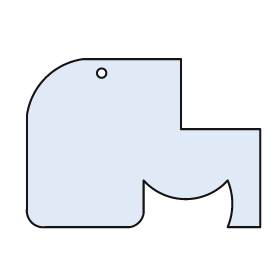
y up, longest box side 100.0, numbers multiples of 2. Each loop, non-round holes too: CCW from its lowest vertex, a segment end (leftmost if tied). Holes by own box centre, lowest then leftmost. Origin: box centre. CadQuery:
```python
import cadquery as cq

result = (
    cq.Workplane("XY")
    .moveTo(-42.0, -36.0)
    .lineTo(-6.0, -36.0)
    .threePointArc((-2.0, -34.0), (0.0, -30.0))
    .lineTo(0.0, -16.0)
    .threePointArc((18.0, -24.0), (36.0, -16.0))
    .threePointArc((38.0, -26.0), (36.0, -36.0))
    .lineTo(50.0, -36.0)
    .lineTo(50.0, 6.0)
    .lineTo(16.0, 6.0)
    .lineTo(16.0, 36.0)
    .lineTo(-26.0, 36.0)
    .threePointArc((-42.0, 28.0), (-50.0, 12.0))
    .lineTo(-50.0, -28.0)
    .threePointArc((-48.0, -34.0), (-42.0, -36.0))
    .close()
    .moveTo(-18.0, 30.0)
    .circle(2.0)
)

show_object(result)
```